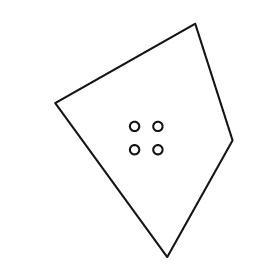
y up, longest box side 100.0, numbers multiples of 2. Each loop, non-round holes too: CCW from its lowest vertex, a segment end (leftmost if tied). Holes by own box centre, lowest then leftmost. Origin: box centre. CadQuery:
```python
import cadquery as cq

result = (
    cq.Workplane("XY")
    .moveTo(10.0, -50.0)
    .lineTo(38.0, 0.0)
    .lineTo(22.0, 50.0)
    .lineTo(-38.0, 16.0)
    .close()
    .moveTo(-4.0, -4.0)
    .circle(2.0)
    .moveTo(6.0, -4.0)
    .circle(2.0)
    .moveTo(-4.0, 6.0)
    .circle(2.0)
    .moveTo(6.0, 6.0)
    .circle(2.0)
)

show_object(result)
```